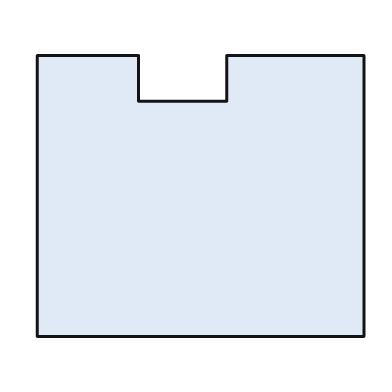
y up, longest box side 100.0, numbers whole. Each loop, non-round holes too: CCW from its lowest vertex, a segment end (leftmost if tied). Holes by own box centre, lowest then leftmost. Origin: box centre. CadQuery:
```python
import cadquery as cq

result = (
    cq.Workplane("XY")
    .moveTo(-50.0, -43.0)
    .lineTo(50.0, -43.0)
    .lineTo(50.0, 43.0)
    .lineTo(8.0, 43.0)
    .lineTo(8.0, 29.0)
    .lineTo(-19.0, 29.0)
    .lineTo(-19.0, 43.0)
    .lineTo(-50.0, 43.0)
    .close()
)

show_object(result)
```